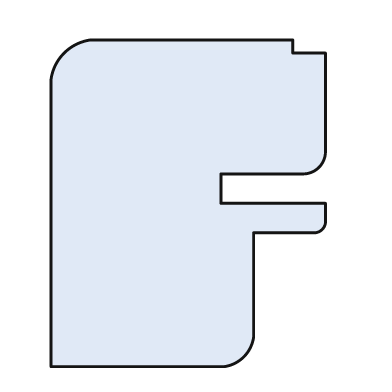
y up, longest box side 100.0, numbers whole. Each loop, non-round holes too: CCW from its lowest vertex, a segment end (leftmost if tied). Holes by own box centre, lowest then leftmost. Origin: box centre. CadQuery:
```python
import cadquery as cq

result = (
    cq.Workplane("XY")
    .moveTo(-42.0, -50.0)
    .lineTo(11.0, -50.0)
    .threePointArc((17.0, -47.0), (20.0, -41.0))
    .lineTo(20.0, -9.0)
    .lineTo(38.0, -9.0)
    .threePointArc((41.0, -8.0), (42.0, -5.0))
    .lineTo(42.0, 0.0)
    .lineTo(10.0, 0.0)
    .lineTo(10.0, 9.0)
    .lineTo(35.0, 9.0)
    .threePointArc((40.0, 11.0), (42.0, 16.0))
    .lineTo(42.0, 46.0)
    .lineTo(32.0, 46.0)
    .lineTo(32.0, 50.0)
    .lineTo(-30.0, 50.0)
    .threePointArc((-38.0, 46.0), (-42.0, 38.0))
    .close()
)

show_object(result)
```